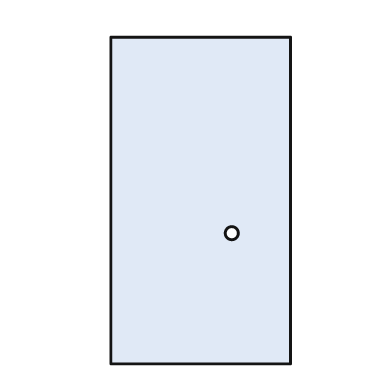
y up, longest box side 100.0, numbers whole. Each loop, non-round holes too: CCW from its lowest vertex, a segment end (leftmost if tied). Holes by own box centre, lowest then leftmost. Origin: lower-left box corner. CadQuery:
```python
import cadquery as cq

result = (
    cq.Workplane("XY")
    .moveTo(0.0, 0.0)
    .lineTo(55.0, 0.0)
    .lineTo(55.0, 100.0)
    .lineTo(0.0, 100.0)
    .close()
    .moveTo(37.0, 40.0)
    .circle(2.0)
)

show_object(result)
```